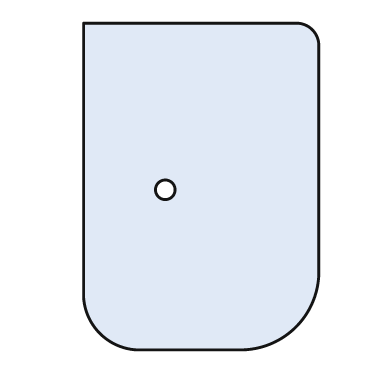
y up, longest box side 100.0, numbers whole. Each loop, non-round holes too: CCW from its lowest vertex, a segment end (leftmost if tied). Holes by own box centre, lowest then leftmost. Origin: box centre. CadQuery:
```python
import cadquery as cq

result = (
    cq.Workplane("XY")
    .moveTo(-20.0, -50.0)
    .lineTo(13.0, -50.0)
    .threePointArc((29.0, -43.0), (36.0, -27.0))
    .lineTo(36.0, 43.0)
    .threePointArc((34.0, 48.0), (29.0, 50.0))
    .lineTo(-36.0, 50.0)
    .lineTo(-36.0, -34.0)
    .threePointArc((-31.0, -45.0), (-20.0, -50.0))
    .close()
    .moveTo(-11.0, -1.0)
    .circle(3.0)
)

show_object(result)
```